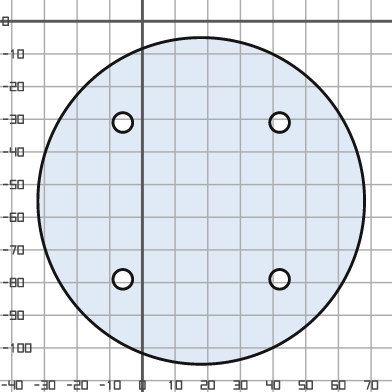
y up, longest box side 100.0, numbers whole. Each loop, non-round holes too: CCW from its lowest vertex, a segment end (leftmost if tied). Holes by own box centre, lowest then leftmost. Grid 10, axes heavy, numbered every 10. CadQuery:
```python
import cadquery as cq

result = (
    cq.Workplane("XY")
    .moveTo(18.0, -55.0)
    .circle(50.0)
    .moveTo(-6.0, -79.0)
    .circle(3.0)
    .moveTo(42.0, -79.0)
    .circle(3.0)
    .moveTo(-6.0, -31.0)
    .circle(3.0)
    .moveTo(42.0, -31.0)
    .circle(3.0)
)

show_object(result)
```